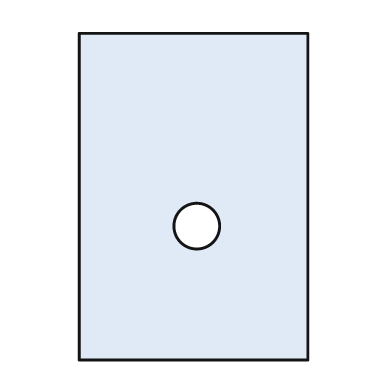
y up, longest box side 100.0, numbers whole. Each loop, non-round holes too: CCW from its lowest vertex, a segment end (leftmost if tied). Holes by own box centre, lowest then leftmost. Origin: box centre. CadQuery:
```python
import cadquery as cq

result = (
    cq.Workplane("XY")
    .moveTo(-35.0, -50.0)
    .lineTo(35.0, -50.0)
    .lineTo(35.0, 50.0)
    .lineTo(-35.0, 50.0)
    .close()
    .moveTo(1.0, -9.0)
    .circle(7.0)
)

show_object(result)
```